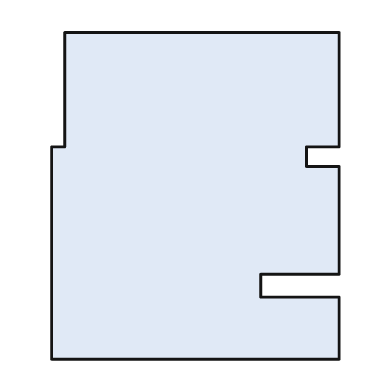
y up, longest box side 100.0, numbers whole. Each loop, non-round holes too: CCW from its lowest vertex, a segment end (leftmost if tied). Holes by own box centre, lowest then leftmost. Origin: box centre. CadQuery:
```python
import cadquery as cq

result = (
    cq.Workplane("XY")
    .moveTo(-44.0, -50.0)
    .lineTo(44.0, -50.0)
    .lineTo(44.0, -31.0)
    .lineTo(20.0, -31.0)
    .lineTo(20.0, -24.0)
    .lineTo(44.0, -24.0)
    .lineTo(44.0, 9.0)
    .lineTo(34.0, 9.0)
    .lineTo(34.0, 15.0)
    .lineTo(44.0, 15.0)
    .lineTo(44.0, 50.0)
    .lineTo(-40.0, 50.0)
    .lineTo(-40.0, 15.0)
    .lineTo(-44.0, 15.0)
    .close()
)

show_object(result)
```